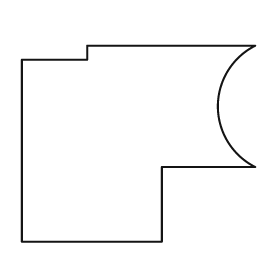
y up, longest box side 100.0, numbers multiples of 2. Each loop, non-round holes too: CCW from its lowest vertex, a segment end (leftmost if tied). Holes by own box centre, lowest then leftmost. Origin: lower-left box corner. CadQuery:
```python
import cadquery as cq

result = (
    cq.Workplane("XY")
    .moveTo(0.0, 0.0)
    .lineTo(60.0, 0.0)
    .lineTo(60.0, 32.0)
    .lineTo(100.0, 32.0)
    .threePointArc((84.0, 58.0), (100.0, 84.0))
    .lineTo(28.0, 84.0)
    .lineTo(28.0, 78.0)
    .lineTo(0.0, 78.0)
    .close()
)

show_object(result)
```